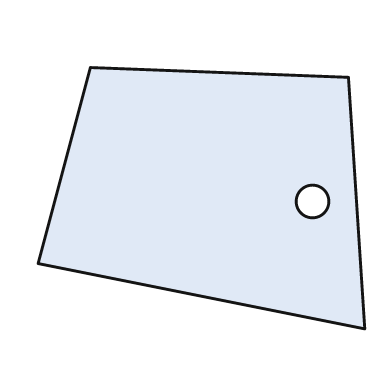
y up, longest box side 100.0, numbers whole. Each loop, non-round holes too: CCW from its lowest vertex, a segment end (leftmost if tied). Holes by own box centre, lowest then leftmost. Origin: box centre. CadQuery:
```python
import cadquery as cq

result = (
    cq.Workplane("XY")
    .moveTo(50.0, -40.0)
    .lineTo(45.0, 37.0)
    .lineTo(-34.0, 40.0)
    .lineTo(-50.0, -20.0)
    .close()
    .moveTo(34.0, -1.0)
    .circle(5.0)
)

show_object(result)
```